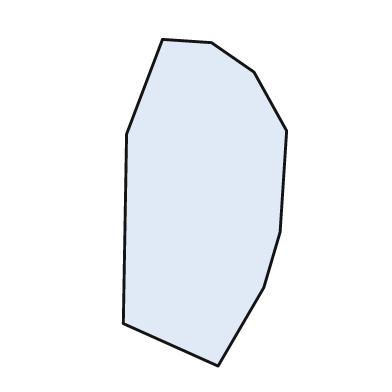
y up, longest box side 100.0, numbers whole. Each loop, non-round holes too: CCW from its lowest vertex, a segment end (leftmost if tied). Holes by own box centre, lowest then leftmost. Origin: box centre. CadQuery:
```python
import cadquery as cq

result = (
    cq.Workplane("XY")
    .moveTo(4.0, -50.0)
    .lineTo(18.0, -26.0)
    .lineTo(23.0, -9.0)
    .lineTo(25.0, 22.0)
    .lineTo(15.0, 40.0)
    .lineTo(2.0, 49.0)
    .lineTo(-13.0, 50.0)
    .lineTo(-24.0, 21.0)
    .lineTo(-25.0, -37.0)
    .close()
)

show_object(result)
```